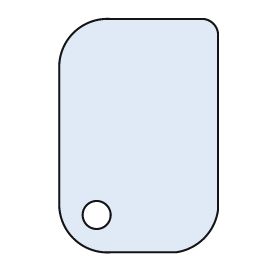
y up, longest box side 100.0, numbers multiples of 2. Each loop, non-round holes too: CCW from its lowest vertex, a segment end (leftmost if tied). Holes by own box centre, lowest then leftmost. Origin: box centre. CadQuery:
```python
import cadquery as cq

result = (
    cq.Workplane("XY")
    .moveTo(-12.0, -50.0)
    .lineTo(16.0, -50.0)
    .threePointArc((28.0, -44.0), (34.0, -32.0))
    .lineTo(34.0, 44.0)
    .threePointArc((32.0, 48.0), (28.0, 50.0))
    .lineTo(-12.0, 50.0)
    .threePointArc((-28.0, 44.0), (-34.0, 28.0))
    .lineTo(-34.0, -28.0)
    .threePointArc((-28.0, -44.0), (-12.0, -50.0))
    .close()
    .moveTo(-18.0, -34.0)
    .circle(6.0)
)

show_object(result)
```